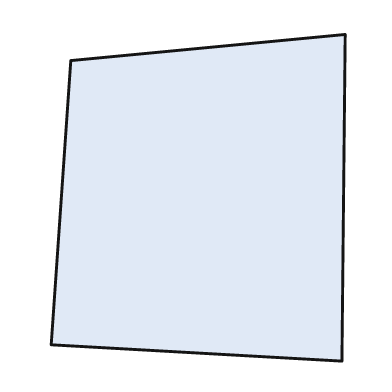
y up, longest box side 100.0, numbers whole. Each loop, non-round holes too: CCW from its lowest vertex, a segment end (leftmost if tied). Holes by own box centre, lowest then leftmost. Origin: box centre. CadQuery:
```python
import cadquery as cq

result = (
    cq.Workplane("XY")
    .moveTo(44.0, -50.0)
    .lineTo(45.0, 50.0)
    .lineTo(-39.0, 42.0)
    .lineTo(-45.0, -45.0)
    .close()
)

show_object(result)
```